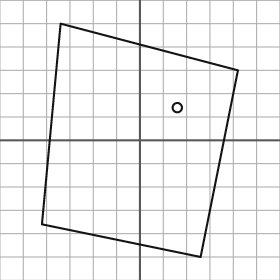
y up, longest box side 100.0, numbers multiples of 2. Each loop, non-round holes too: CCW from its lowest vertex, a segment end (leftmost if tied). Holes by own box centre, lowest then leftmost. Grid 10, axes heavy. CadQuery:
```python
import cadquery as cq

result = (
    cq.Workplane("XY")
    .moveTo(26.0, -50.0)
    .lineTo(42.0, 30.0)
    .lineTo(-34.0, 50.0)
    .lineTo(-42.0, -36.0)
    .close()
    .moveTo(16.0, 14.0)
    .circle(2.0)
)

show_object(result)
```